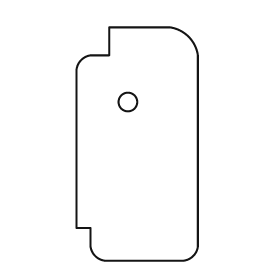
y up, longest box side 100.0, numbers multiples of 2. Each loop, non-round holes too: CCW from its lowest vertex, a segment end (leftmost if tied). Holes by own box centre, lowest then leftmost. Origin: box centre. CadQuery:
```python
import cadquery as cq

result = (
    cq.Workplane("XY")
    .moveTo(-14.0, -50.0)
    .lineTo(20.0, -50.0)
    .threePointArc((24.0, -48.0), (26.0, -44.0))
    .lineTo(26.0, 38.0)
    .threePointArc((22.0, 46.0), (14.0, 50.0))
    .lineTo(-12.0, 50.0)
    .lineTo(-12.0, 38.0)
    .lineTo(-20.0, 38.0)
    .threePointArc((-24.0, 36.0), (-26.0, 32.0))
    .lineTo(-26.0, -36.0)
    .lineTo(-20.0, -36.0)
    .lineTo(-20.0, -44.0)
    .threePointArc((-18.0, -48.0), (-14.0, -50.0))
    .close()
    .moveTo(-4.0, 18.0)
    .circle(4.0)
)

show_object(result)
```